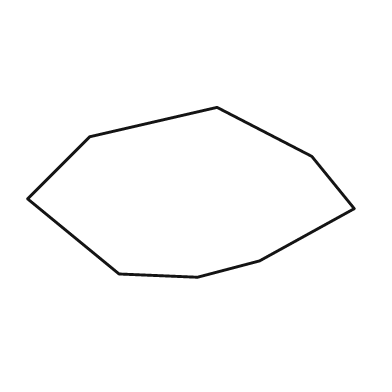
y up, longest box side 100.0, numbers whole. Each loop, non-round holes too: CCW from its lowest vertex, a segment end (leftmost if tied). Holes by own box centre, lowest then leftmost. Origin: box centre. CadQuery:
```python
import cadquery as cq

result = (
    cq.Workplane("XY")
    .moveTo(2.0, -26.0)
    .lineTo(21.0, -21.0)
    .lineTo(50.0, -5.0)
    .lineTo(37.0, 11.0)
    .lineTo(8.0, 26.0)
    .lineTo(-31.0, 17.0)
    .lineTo(-50.0, -2.0)
    .lineTo(-22.0, -25.0)
    .close()
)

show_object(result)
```